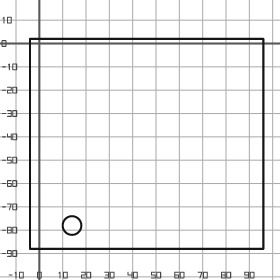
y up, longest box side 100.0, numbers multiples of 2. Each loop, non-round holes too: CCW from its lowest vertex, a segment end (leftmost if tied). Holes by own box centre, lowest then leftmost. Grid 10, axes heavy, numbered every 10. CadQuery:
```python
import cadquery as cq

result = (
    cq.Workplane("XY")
    .moveTo(-4.0, -88.0)
    .lineTo(96.0, -88.0)
    .lineTo(96.0, 2.0)
    .lineTo(-4.0, 2.0)
    .close()
    .moveTo(14.0, -78.0)
    .circle(4.0)
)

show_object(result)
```